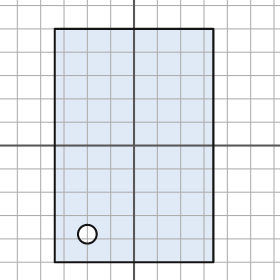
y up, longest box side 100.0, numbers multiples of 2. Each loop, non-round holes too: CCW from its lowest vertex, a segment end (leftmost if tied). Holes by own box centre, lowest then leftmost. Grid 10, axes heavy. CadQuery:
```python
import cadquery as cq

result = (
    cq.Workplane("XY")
    .moveTo(-34.0, -50.0)
    .lineTo(34.0, -50.0)
    .lineTo(34.0, 50.0)
    .lineTo(-34.0, 50.0)
    .close()
    .moveTo(-20.0, -38.0)
    .circle(4.0)
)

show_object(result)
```